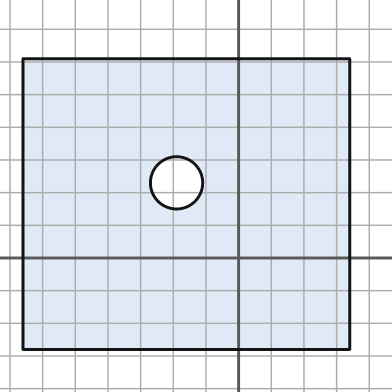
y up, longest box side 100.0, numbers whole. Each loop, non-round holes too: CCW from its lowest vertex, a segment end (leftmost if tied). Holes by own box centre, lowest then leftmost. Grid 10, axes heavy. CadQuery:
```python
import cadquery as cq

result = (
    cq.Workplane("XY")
    .moveTo(-66.0, -28.0)
    .lineTo(34.0, -28.0)
    .lineTo(34.0, 61.0)
    .lineTo(-66.0, 61.0)
    .close()
    .moveTo(-19.0, 23.0)
    .circle(8.0)
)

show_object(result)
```